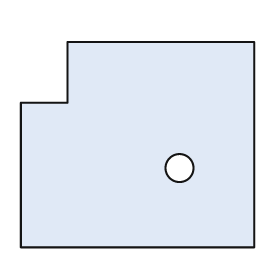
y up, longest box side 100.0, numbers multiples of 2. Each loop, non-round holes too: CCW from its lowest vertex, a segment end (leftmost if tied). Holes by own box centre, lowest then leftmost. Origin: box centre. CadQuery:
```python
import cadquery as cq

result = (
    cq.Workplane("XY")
    .moveTo(-50.0, -44.0)
    .lineTo(50.0, -44.0)
    .lineTo(50.0, 44.0)
    .lineTo(-30.0, 44.0)
    .lineTo(-30.0, 18.0)
    .lineTo(-50.0, 18.0)
    .close()
    .moveTo(18.0, -10.0)
    .circle(6.0)
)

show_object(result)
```